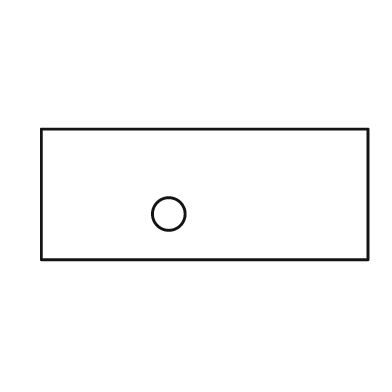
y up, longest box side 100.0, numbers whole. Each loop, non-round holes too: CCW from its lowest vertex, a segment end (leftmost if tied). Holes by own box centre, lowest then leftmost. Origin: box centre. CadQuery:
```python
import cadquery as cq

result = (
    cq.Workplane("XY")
    .moveTo(-50.0, -20.0)
    .lineTo(50.0, -20.0)
    .lineTo(50.0, 20.0)
    .lineTo(-50.0, 20.0)
    .close()
    .moveTo(-11.0, -6.0)
    .circle(5.0)
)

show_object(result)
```